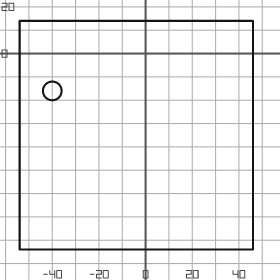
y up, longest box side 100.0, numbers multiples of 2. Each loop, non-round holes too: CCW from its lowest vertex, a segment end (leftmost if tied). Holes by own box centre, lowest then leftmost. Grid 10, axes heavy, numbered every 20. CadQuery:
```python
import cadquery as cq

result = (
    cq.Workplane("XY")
    .moveTo(-54.0, -84.0)
    .lineTo(46.0, -84.0)
    .lineTo(46.0, 14.0)
    .lineTo(-54.0, 14.0)
    .close()
    .moveTo(-40.0, -16.0)
    .circle(4.0)
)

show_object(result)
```